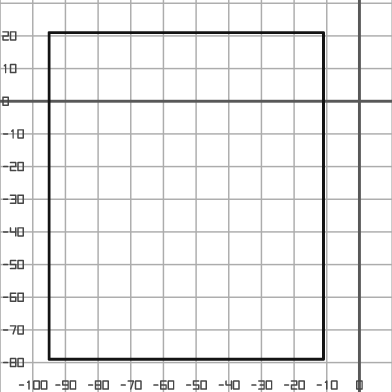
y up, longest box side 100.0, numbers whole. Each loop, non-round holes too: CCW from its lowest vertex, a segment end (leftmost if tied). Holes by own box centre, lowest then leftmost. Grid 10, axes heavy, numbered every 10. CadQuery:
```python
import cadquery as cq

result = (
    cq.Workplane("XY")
    .moveTo(-95.0, -79.0)
    .lineTo(-11.0, -79.0)
    .lineTo(-11.0, 21.0)
    .lineTo(-95.0, 21.0)
    .close()
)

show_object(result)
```